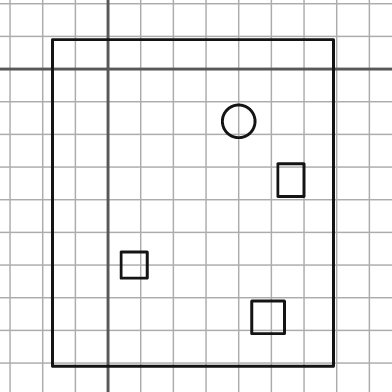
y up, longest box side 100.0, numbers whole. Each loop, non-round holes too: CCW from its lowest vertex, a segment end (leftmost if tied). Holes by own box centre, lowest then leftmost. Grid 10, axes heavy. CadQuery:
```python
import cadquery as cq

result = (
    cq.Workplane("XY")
    .moveTo(-17.0, -91.0)
    .lineTo(69.0, -91.0)
    .lineTo(69.0, 9.0)
    .lineTo(-17.0, 9.0)
    .close()
    .moveTo(44.0, -81.0)
    .lineTo(54.0, -81.0)
    .lineTo(54.0, -71.0)
    .lineTo(44.0, -71.0)
    .close()
    .moveTo(4.0, -64.0)
    .lineTo(12.0, -64.0)
    .lineTo(12.0, -56.0)
    .lineTo(4.0, -56.0)
    .close()
    .moveTo(52.0, -39.0)
    .lineTo(60.0, -39.0)
    .lineTo(60.0, -29.0)
    .lineTo(52.0, -29.0)
    .close()
    .moveTo(40.0, -16.0)
    .circle(5.0)
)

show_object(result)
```